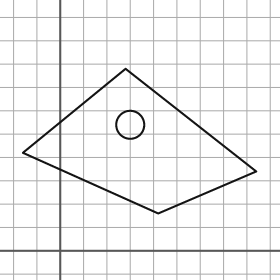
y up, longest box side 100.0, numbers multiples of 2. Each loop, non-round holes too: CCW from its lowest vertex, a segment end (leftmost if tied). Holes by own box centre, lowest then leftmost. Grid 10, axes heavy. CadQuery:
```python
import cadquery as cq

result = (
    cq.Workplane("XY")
    .moveTo(42.0, 16.0)
    .lineTo(84.0, 34.0)
    .lineTo(28.0, 78.0)
    .lineTo(-16.0, 42.0)
    .close()
    .moveTo(30.0, 54.0)
    .circle(6.0)
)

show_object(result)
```